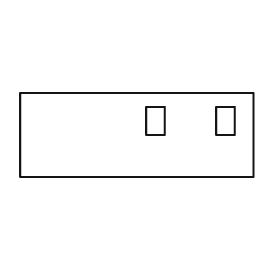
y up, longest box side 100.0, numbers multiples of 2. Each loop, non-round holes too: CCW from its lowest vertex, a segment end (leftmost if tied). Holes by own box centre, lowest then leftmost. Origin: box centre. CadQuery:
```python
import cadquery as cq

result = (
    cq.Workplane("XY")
    .moveTo(-50.0, -18.0)
    .lineTo(50.0, -18.0)
    .lineTo(50.0, 18.0)
    .lineTo(-50.0, 18.0)
    .close()
    .moveTo(4.0, 0.0)
    .lineTo(12.0, 0.0)
    .lineTo(12.0, 12.0)
    .lineTo(4.0, 12.0)
    .close()
    .moveTo(34.0, 0.0)
    .lineTo(42.0, 0.0)
    .lineTo(42.0, 12.0)
    .lineTo(34.0, 12.0)
    .close()
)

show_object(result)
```